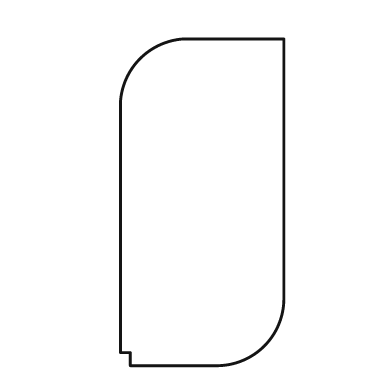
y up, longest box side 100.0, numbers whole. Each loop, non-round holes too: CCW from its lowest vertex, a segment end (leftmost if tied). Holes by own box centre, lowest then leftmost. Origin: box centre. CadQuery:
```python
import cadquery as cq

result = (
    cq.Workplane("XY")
    .moveTo(-22.0, -50.0)
    .lineTo(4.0, -50.0)
    .threePointArc((19.0, -44.0), (25.0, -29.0))
    .lineTo(25.0, 50.0)
    .lineTo(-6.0, 50.0)
    .threePointArc((-19.0, 44.0), (-25.0, 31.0))
    .lineTo(-25.0, -46.0)
    .lineTo(-22.0, -46.0)
    .close()
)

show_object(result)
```